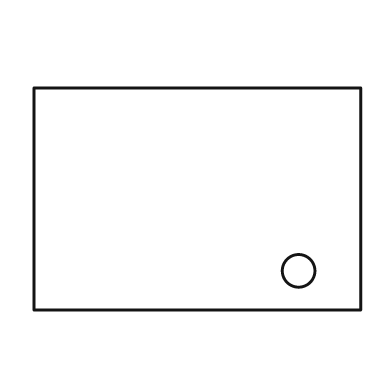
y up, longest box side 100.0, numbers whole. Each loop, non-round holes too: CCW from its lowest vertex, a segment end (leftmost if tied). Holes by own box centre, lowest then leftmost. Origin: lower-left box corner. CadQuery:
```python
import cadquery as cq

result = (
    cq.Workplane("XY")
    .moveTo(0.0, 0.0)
    .lineTo(100.0, 0.0)
    .lineTo(100.0, 68.0)
    .lineTo(0.0, 68.0)
    .close()
    .moveTo(81.0, 12.0)
    .circle(5.0)
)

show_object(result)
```